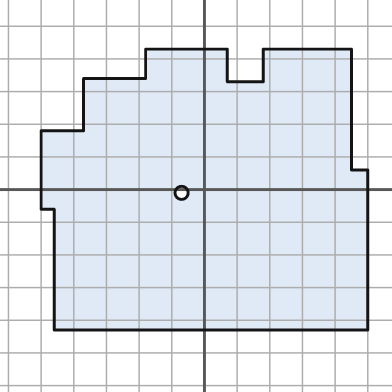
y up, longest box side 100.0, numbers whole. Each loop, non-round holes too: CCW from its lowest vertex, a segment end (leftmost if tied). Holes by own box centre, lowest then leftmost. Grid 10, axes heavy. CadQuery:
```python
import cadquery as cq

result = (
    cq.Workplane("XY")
    .moveTo(-46.0, -43.0)
    .lineTo(50.0, -43.0)
    .lineTo(50.0, 6.0)
    .lineTo(45.0, 6.0)
    .lineTo(45.0, 43.0)
    .lineTo(18.0, 43.0)
    .lineTo(18.0, 33.0)
    .lineTo(7.0, 33.0)
    .lineTo(7.0, 43.0)
    .lineTo(-18.0, 43.0)
    .lineTo(-18.0, 34.0)
    .lineTo(-37.0, 34.0)
    .lineTo(-37.0, 18.0)
    .lineTo(-50.0, 18.0)
    .lineTo(-50.0, -6.0)
    .lineTo(-46.0, -6.0)
    .close()
    .moveTo(-7.0, -1.0)
    .circle(2.0)
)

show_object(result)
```